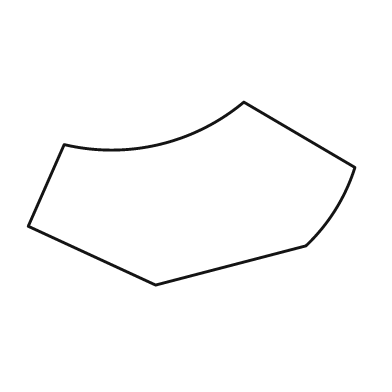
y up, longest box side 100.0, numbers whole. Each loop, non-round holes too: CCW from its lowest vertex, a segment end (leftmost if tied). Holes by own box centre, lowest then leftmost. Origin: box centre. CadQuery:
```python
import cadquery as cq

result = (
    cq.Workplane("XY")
    .moveTo(-11.0, -28.0)
    .lineTo(35.0, -16.0)
    .threePointArc((44.0, -5.0), (50.0, 8.0))
    .lineTo(16.0, 28.0)
    .threePointArc((-10.0, 15.0), (-39.0, 15.0))
    .lineTo(-50.0, -10.0)
    .close()
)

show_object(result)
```